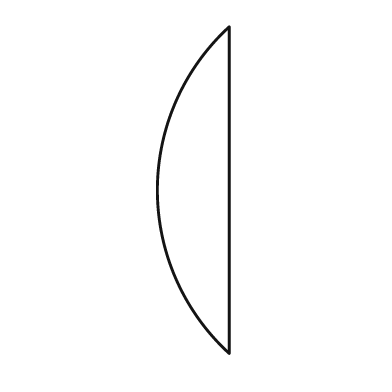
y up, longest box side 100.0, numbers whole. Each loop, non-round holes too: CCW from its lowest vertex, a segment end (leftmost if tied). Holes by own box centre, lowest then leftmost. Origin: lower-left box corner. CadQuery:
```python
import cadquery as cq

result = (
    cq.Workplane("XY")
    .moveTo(22.0, 0.0)
    .lineTo(22.0, 100.0)
    .threePointArc((0.0, 50.0), (22.0, 0.0))
    .close()
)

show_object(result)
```